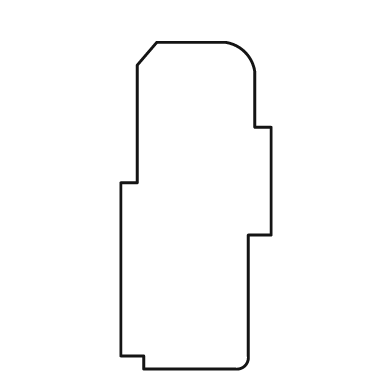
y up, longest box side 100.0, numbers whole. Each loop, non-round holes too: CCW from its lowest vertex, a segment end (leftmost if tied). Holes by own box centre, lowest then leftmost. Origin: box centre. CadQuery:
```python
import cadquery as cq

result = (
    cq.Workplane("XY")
    .moveTo(-16.0, -50.0)
    .lineTo(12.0, -50.0)
    .threePointArc((15.0, -49.0), (16.0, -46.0))
    .lineTo(16.0, -9.0)
    .lineTo(23.0, -9.0)
    .lineTo(23.0, 24.0)
    .lineTo(18.0, 24.0)
    .lineTo(18.0, 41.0)
    .threePointArc((15.0, 47.0), (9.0, 50.0))
    .lineTo(-12.0, 50.0)
    .lineTo(-18.0, 43.0)
    .lineTo(-18.0, 7.0)
    .lineTo(-23.0, 7.0)
    .lineTo(-23.0, -46.0)
    .lineTo(-16.0, -46.0)
    .close()
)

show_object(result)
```